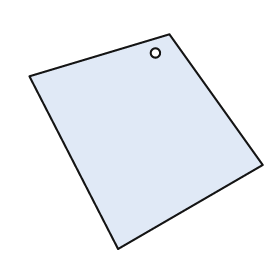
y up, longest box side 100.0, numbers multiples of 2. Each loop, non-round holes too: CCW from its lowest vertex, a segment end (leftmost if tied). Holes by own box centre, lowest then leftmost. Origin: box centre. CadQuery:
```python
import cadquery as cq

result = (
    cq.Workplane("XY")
    .moveTo(-12.0, -46.0)
    .lineTo(50.0, -10.0)
    .lineTo(10.0, 46.0)
    .lineTo(-50.0, 28.0)
    .close()
    .moveTo(4.0, 38.0)
    .circle(2.0)
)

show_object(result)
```